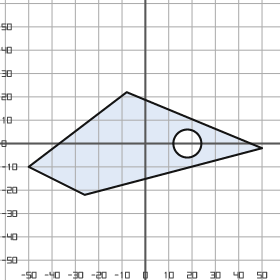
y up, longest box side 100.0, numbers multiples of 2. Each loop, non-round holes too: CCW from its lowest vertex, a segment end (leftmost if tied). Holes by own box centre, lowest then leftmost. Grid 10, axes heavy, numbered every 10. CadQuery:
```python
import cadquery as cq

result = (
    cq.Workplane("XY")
    .moveTo(-26.0, -22.0)
    .lineTo(50.0, -2.0)
    .lineTo(-8.0, 22.0)
    .lineTo(-50.0, -10.0)
    .close()
    .moveTo(18.0, 0.0)
    .circle(6.0)
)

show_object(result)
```